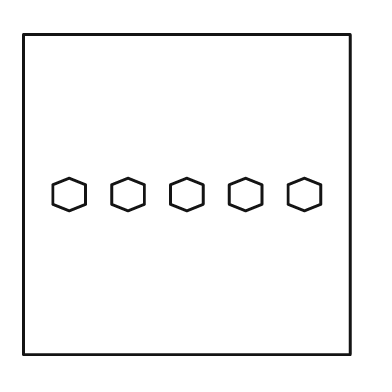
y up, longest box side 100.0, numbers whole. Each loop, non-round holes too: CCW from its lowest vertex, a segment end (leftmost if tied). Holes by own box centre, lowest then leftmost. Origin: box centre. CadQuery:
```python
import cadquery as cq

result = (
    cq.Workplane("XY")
    .moveTo(-50.0, -49.0)
    .lineTo(50.0, -49.0)
    .lineTo(50.0, 49.0)
    .lineTo(-50.0, 49.0)
    .close()
    .moveTo(-36.0, -5.0)
    .lineTo(-31.0, -3.0)
    .lineTo(-31.0, 3.0)
    .lineTo(-36.0, 5.0)
    .lineTo(-41.0, 3.0)
    .lineTo(-41.0, -3.0)
    .close()
    .moveTo(-18.0, -5.0)
    .lineTo(-13.0, -3.0)
    .lineTo(-13.0, 3.0)
    .lineTo(-18.0, 5.0)
    .lineTo(-23.0, 3.0)
    .lineTo(-23.0, -3.0)
    .close()
    .moveTo(0.0, -5.0)
    .lineTo(5.0, -3.0)
    .lineTo(5.0, 3.0)
    .lineTo(0.0, 5.0)
    .lineTo(-5.0, 3.0)
    .lineTo(-5.0, -3.0)
    .close()
    .moveTo(18.0, -5.0)
    .lineTo(23.0, -3.0)
    .lineTo(23.0, 3.0)
    .lineTo(18.0, 5.0)
    .lineTo(13.0, 3.0)
    .lineTo(13.0, -3.0)
    .close()
    .moveTo(36.0, -5.0)
    .lineTo(41.0, -3.0)
    .lineTo(41.0, 3.0)
    .lineTo(36.0, 5.0)
    .lineTo(31.0, 3.0)
    .lineTo(31.0, -3.0)
    .close()
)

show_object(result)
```